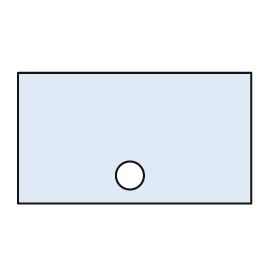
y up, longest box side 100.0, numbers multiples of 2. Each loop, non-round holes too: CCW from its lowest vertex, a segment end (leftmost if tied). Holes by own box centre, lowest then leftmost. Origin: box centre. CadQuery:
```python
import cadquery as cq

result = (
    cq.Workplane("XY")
    .moveTo(-50.0, -28.0)
    .lineTo(50.0, -28.0)
    .lineTo(50.0, 28.0)
    .lineTo(-50.0, 28.0)
    .close()
    .moveTo(-2.0, -16.0)
    .circle(6.0)
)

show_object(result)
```